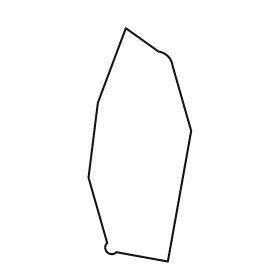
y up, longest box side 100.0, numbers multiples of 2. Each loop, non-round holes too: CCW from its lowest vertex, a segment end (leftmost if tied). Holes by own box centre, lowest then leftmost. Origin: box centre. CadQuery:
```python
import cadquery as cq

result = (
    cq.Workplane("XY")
    .moveTo(12.0, -50.0)
    .lineTo(22.0, 6.0)
    .lineTo(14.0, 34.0)
    .threePointArc((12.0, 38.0), (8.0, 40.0))
    .lineTo(-6.0, 50.0)
    .lineTo(-18.0, 18.0)
    .lineTo(-22.0, -14.0)
    .lineTo(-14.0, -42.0)
    .threePointArc((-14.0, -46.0), (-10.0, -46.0))
    .close()
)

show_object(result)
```